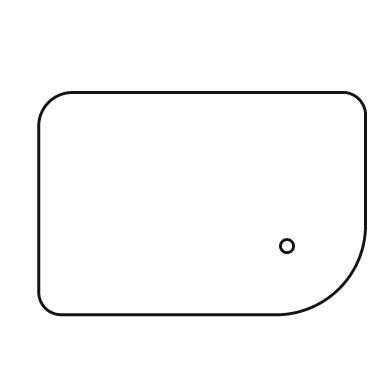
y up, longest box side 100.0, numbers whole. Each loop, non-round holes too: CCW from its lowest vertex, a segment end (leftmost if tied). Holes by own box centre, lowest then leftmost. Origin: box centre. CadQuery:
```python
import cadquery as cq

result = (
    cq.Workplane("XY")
    .moveTo(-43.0, -34.0)
    .lineTo(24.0, -34.0)
    .threePointArc((42.0, -26.0), (50.0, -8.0))
    .lineTo(50.0, 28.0)
    .threePointArc((48.0, 32.0), (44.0, 34.0))
    .lineTo(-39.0, 34.0)
    .threePointArc((-47.0, 31.0), (-50.0, 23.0))
    .lineTo(-50.0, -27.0)
    .threePointArc((-48.0, -32.0), (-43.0, -34.0))
    .close()
    .moveTo(26.0, -13.0)
    .circle(2.0)
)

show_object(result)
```